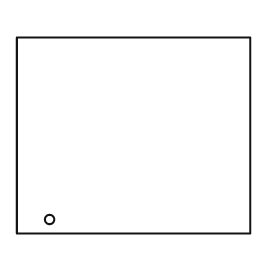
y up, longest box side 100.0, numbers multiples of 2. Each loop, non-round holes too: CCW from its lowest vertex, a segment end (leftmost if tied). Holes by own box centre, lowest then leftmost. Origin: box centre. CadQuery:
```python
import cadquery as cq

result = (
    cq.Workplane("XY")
    .moveTo(-50.0, -42.0)
    .lineTo(50.0, -42.0)
    .lineTo(50.0, 42.0)
    .lineTo(-50.0, 42.0)
    .close()
    .moveTo(-36.0, -36.0)
    .circle(2.0)
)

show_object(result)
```